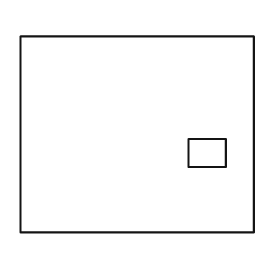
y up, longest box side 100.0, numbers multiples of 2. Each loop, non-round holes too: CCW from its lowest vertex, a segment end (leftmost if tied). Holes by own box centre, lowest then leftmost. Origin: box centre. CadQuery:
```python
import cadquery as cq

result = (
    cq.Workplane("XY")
    .moveTo(-50.0, -42.0)
    .lineTo(50.0, -42.0)
    .lineTo(50.0, 42.0)
    .lineTo(-50.0, 42.0)
    .close()
    .moveTo(22.0, -14.0)
    .lineTo(38.0, -14.0)
    .lineTo(38.0, -2.0)
    .lineTo(22.0, -2.0)
    .close()
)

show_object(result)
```